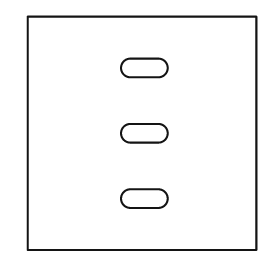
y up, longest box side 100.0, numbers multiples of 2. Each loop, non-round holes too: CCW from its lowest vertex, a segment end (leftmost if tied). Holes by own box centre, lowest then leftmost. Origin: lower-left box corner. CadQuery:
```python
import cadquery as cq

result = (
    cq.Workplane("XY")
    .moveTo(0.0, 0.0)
    .lineTo(98.0, 0.0)
    .lineTo(98.0, 100.0)
    .lineTo(0.0, 100.0)
    .close()
    .moveTo(44.0, 18.0)
    .lineTo(56.0, 18.0)
    .threePointArc((60.0, 22.0), (56.0, 26.0))
    .lineTo(44.0, 26.0)
    .threePointArc((40.0, 22.0), (44.0, 18.0))
    .close()
    .moveTo(44.0, 46.0)
    .lineTo(56.0, 46.0)
    .threePointArc((60.0, 50.0), (56.0, 54.0))
    .lineTo(44.0, 54.0)
    .threePointArc((40.0, 50.0), (44.0, 46.0))
    .close()
    .moveTo(44.0, 74.0)
    .lineTo(56.0, 74.0)
    .threePointArc((60.0, 78.0), (56.0, 82.0))
    .lineTo(44.0, 82.0)
    .threePointArc((40.0, 78.0), (44.0, 74.0))
    .close()
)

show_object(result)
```